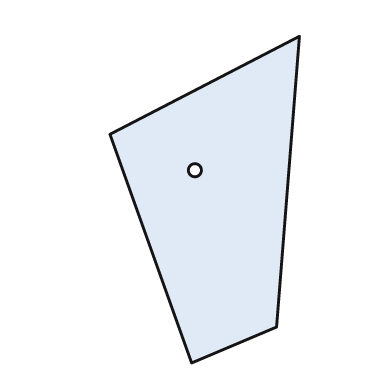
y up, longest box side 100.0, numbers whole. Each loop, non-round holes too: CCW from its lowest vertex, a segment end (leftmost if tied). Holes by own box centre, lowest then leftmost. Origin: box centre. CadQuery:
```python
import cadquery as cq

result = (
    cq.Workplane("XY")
    .moveTo(-4.0, -50.0)
    .lineTo(22.0, -39.0)
    .lineTo(29.0, 50.0)
    .lineTo(-29.0, 20.0)
    .close()
    .moveTo(-3.0, 9.0)
    .circle(2.0)
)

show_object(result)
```